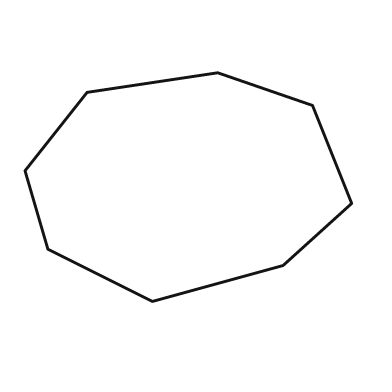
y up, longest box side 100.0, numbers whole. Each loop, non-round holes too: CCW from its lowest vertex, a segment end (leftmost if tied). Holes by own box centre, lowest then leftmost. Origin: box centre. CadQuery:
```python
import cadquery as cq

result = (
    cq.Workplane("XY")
    .moveTo(-11.0, -35.0)
    .lineTo(29.0, -24.0)
    .lineTo(50.0, -5.0)
    .lineTo(38.0, 25.0)
    .lineTo(9.0, 35.0)
    .lineTo(-31.0, 29.0)
    .lineTo(-50.0, 5.0)
    .lineTo(-43.0, -19.0)
    .close()
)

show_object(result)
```